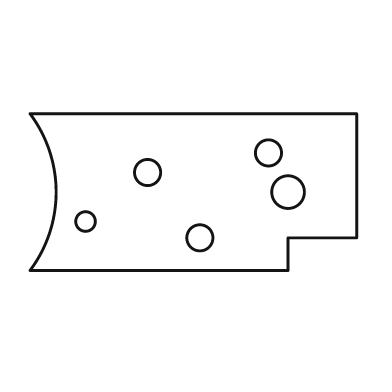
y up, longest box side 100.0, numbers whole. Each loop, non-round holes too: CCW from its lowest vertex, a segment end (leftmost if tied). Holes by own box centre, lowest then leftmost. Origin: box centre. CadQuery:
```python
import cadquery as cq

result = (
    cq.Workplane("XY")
    .moveTo(-50.0, -24.0)
    .lineTo(29.0, -24.0)
    .lineTo(29.0, -14.0)
    .lineTo(50.0, -14.0)
    .lineTo(50.0, 24.0)
    .lineTo(-50.0, 24.0)
    .threePointArc((-42.0, 0.0), (-50.0, -24.0))
    .close()
    .moveTo(2.0, -14.0)
    .circle(4.0)
    .moveTo(-33.0, -9.0)
    .circle(3.0)
    .moveTo(29.0, 0.0)
    .circle(5.0)
    .moveTo(-14.0, 6.0)
    .circle(4.0)
    .moveTo(23.0, 12.0)
    .circle(4.0)
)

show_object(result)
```